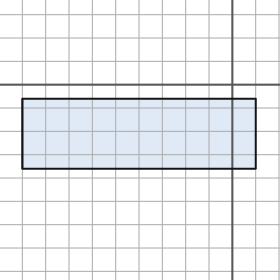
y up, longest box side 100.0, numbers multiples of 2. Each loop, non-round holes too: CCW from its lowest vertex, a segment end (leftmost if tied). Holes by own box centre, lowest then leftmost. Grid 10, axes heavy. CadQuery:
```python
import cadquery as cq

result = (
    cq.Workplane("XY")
    .moveTo(-90.0, -36.0)
    .lineTo(10.0, -36.0)
    .lineTo(10.0, -6.0)
    .lineTo(-90.0, -6.0)
    .close()
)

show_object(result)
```